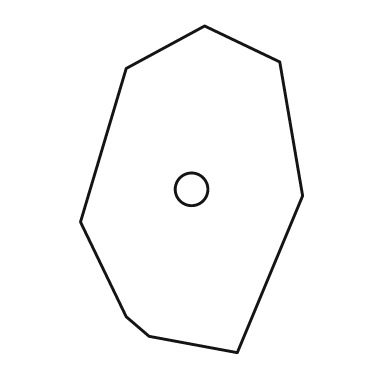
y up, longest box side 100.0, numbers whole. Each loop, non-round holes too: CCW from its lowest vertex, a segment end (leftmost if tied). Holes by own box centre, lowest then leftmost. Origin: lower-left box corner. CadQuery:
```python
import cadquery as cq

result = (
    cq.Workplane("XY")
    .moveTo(48.0, 0.0)
    .lineTo(68.0, 48.0)
    .lineTo(61.0, 89.0)
    .lineTo(38.0, 100.0)
    .lineTo(14.0, 87.0)
    .lineTo(0.0, 40.0)
    .lineTo(14.0, 11.0)
    .lineTo(21.0, 5.0)
    .close()
    .moveTo(34.0, 50.0)
    .circle(5.0)
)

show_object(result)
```